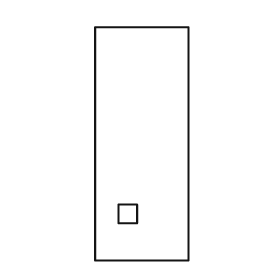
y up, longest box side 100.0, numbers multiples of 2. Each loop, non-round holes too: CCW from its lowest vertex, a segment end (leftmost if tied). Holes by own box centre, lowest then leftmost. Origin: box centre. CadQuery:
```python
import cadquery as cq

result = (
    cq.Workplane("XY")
    .moveTo(-20.0, -50.0)
    .lineTo(20.0, -50.0)
    .lineTo(20.0, 50.0)
    .lineTo(-20.0, 50.0)
    .close()
    .moveTo(-10.0, -34.0)
    .lineTo(-2.0, -34.0)
    .lineTo(-2.0, -26.0)
    .lineTo(-10.0, -26.0)
    .close()
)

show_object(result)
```